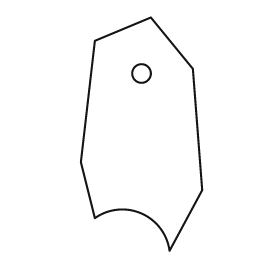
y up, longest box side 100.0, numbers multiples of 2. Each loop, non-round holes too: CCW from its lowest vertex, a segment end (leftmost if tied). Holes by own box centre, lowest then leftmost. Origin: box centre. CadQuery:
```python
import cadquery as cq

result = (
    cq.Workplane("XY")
    .moveTo(12.0, -50.0)
    .lineTo(26.0, -24.0)
    .lineTo(22.0, 28.0)
    .lineTo(4.0, 50.0)
    .lineTo(-20.0, 40.0)
    .lineTo(-26.0, -12.0)
    .lineTo(-20.0, -36.0)
    .threePointArc((0.0, -34.0), (12.0, -50.0))
    .close()
    .moveTo(0.0, 26.0)
    .circle(4.0)
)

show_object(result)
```